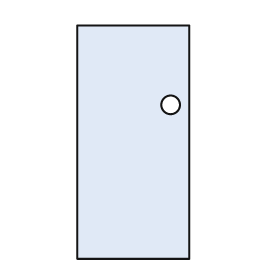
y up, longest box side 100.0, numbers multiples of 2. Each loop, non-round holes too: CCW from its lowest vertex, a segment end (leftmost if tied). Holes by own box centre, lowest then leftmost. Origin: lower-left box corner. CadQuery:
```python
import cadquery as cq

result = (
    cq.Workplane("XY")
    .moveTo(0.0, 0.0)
    .lineTo(48.0, 0.0)
    .lineTo(48.0, 100.0)
    .lineTo(0.0, 100.0)
    .close()
    .moveTo(40.0, 66.0)
    .circle(4.0)
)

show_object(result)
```